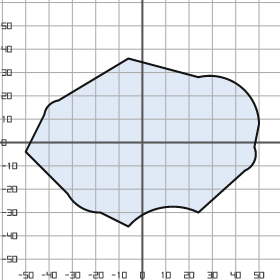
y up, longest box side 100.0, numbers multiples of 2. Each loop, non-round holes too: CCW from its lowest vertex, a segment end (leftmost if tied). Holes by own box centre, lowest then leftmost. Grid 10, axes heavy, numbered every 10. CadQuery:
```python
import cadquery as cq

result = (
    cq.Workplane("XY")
    .moveTo(-6.0, -36.0)
    .threePointArc((8.0, -28.0), (24.0, -30.0))
    .lineTo(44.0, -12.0)
    .threePointArc((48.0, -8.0), (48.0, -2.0))
    .lineTo(50.0, 8.0)
    .threePointArc((42.0, 24.0), (24.0, 28.0))
    .lineTo(-6.0, 36.0)
    .lineTo(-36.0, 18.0)
    .threePointArc((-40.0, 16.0), (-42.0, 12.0))
    .lineTo(-50.0, -4.0)
    .lineTo(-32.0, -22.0)
    .threePointArc((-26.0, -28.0), (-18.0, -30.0))
    .close()
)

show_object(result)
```